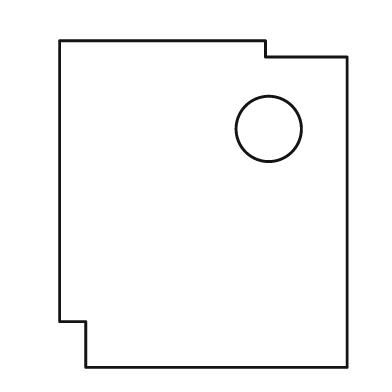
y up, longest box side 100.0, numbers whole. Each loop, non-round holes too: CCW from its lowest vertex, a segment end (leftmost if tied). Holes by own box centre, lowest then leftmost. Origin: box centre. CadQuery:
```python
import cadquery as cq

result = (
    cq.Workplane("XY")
    .moveTo(-36.0, -50.0)
    .lineTo(44.0, -50.0)
    .lineTo(44.0, 45.0)
    .lineTo(19.0, 45.0)
    .lineTo(19.0, 50.0)
    .lineTo(-44.0, 50.0)
    .lineTo(-44.0, -36.0)
    .lineTo(-36.0, -36.0)
    .close()
    .moveTo(20.0, 23.0)
    .circle(10.0)
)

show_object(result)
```